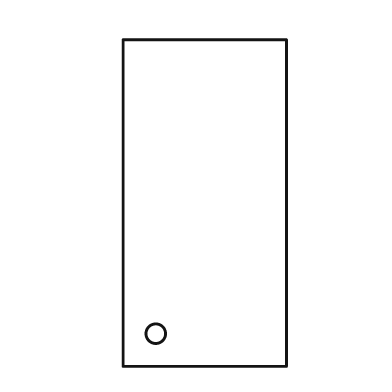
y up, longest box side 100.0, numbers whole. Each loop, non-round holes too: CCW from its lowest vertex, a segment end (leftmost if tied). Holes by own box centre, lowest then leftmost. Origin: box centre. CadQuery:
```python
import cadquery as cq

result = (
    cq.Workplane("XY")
    .moveTo(-25.0, -50.0)
    .lineTo(25.0, -50.0)
    .lineTo(25.0, 50.0)
    .lineTo(-25.0, 50.0)
    .close()
    .moveTo(-15.0, -40.0)
    .circle(3.0)
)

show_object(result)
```